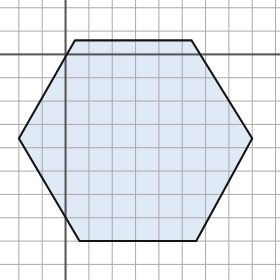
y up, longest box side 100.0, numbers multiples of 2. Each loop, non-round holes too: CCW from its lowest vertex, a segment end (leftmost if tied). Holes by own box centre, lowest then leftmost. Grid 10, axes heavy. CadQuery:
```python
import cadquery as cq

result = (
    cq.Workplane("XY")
    .moveTo(6.0, -80.0)
    .lineTo(56.0, -80.0)
    .lineTo(80.0, -36.0)
    .lineTo(54.0, 6.0)
    .lineTo(4.0, 6.0)
    .lineTo(-20.0, -36.0)
    .close()
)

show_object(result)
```